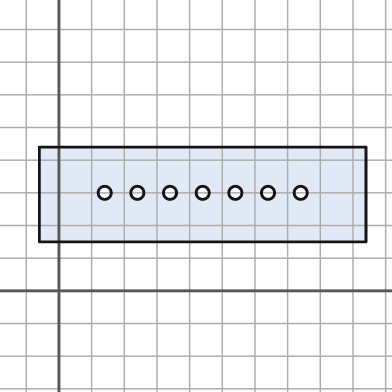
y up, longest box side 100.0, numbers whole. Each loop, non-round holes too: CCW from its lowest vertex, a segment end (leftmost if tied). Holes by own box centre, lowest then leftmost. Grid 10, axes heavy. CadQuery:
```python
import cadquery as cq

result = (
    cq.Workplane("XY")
    .moveTo(-6.0, 15.0)
    .lineTo(94.0, 15.0)
    .lineTo(94.0, 44.0)
    .lineTo(-6.0, 44.0)
    .close()
    .moveTo(14.0, 30.0)
    .circle(2.0)
    .moveTo(24.0, 30.0)
    .circle(2.0)
    .moveTo(34.0, 30.0)
    .circle(2.0)
    .moveTo(44.0, 30.0)
    .circle(2.0)
    .moveTo(54.0, 30.0)
    .circle(2.0)
    .moveTo(64.0, 30.0)
    .circle(2.0)
    .moveTo(74.0, 30.0)
    .circle(2.0)
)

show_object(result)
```